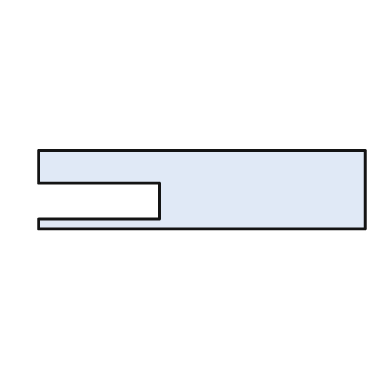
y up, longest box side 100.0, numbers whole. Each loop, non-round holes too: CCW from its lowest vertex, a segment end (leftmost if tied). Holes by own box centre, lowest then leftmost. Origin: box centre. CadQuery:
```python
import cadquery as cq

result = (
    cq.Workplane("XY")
    .moveTo(-50.0, -12.0)
    .lineTo(50.0, -12.0)
    .lineTo(50.0, 12.0)
    .lineTo(-50.0, 12.0)
    .lineTo(-50.0, 2.0)
    .lineTo(-13.0, 2.0)
    .lineTo(-13.0, -9.0)
    .lineTo(-50.0, -9.0)
    .close()
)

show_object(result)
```